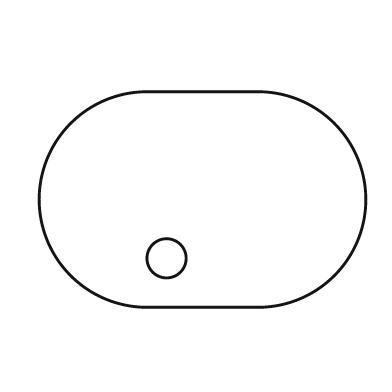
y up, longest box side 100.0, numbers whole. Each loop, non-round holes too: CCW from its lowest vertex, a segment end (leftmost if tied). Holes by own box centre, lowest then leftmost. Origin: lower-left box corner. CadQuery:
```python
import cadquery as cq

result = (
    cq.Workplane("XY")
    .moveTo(33.0, 0.0)
    .lineTo(67.0, 0.0)
    .threePointArc((100.0, 33.0), (67.0, 66.0))
    .lineTo(33.0, 66.0)
    .threePointArc((0.0, 33.0), (33.0, 0.0))
    .close()
    .moveTo(39.0, 15.0)
    .circle(6.0)
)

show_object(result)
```